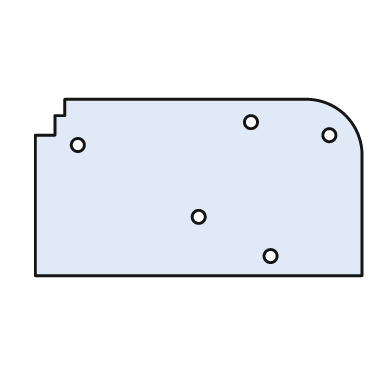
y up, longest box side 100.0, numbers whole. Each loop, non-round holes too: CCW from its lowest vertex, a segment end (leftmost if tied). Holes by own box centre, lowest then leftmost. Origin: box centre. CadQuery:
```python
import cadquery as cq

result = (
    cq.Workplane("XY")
    .moveTo(-50.0, -27.0)
    .lineTo(50.0, -27.0)
    .lineTo(50.0, 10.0)
    .threePointArc((45.0, 22.0), (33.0, 27.0))
    .lineTo(-41.0, 27.0)
    .lineTo(-41.0, 22.0)
    .lineTo(-44.0, 22.0)
    .lineTo(-44.0, 16.0)
    .lineTo(-50.0, 16.0)
    .close()
    .moveTo(22.0, -21.0)
    .circle(2.0)
    .moveTo(0.0, -9.0)
    .circle(2.0)
    .moveTo(-37.0, 13.0)
    .circle(2.0)
    .moveTo(40.0, 16.0)
    .circle(2.0)
    .moveTo(16.0, 20.0)
    .circle(2.0)
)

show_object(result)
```